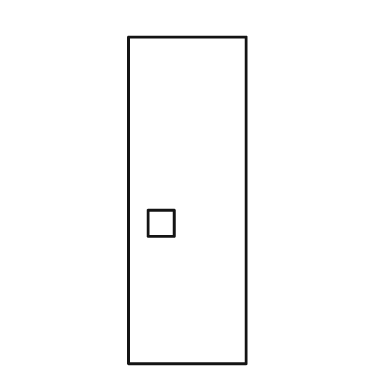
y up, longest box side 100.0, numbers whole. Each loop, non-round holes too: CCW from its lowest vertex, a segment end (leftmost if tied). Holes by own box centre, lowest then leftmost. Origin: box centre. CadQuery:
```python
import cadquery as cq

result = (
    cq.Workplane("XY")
    .moveTo(-18.0, -50.0)
    .lineTo(18.0, -50.0)
    .lineTo(18.0, 50.0)
    .lineTo(-18.0, 50.0)
    .close()
    .moveTo(-12.0, -11.0)
    .lineTo(-4.0, -11.0)
    .lineTo(-4.0, -3.0)
    .lineTo(-12.0, -3.0)
    .close()
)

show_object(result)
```